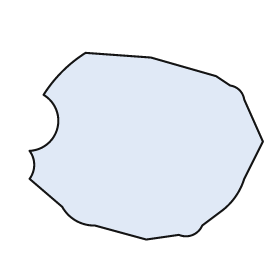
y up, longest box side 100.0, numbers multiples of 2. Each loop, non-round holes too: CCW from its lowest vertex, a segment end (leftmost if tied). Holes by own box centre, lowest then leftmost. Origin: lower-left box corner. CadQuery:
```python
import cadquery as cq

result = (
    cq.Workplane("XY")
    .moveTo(50.0, 0.0)
    .lineTo(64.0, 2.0)
    .threePointArc((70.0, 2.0), (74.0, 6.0))
    .lineTo(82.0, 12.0)
    .threePointArc((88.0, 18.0), (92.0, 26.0))
    .lineTo(100.0, 42.0)
    .lineTo(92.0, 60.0)
    .threePointArc((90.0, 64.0), (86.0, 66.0))
    .lineTo(80.0, 70.0)
    .lineTo(52.0, 78.0)
    .lineTo(24.0, 80.0)
    .threePointArc((14.0, 72.0), (6.0, 62.0))
    .threePointArc((12.0, 48.0), (0.0, 38.0))
    .threePointArc((2.0, 32.0), (0.0, 26.0))
    .lineTo(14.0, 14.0)
    .threePointArc((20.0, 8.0), (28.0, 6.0))
    .close()
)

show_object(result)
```